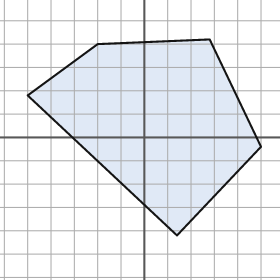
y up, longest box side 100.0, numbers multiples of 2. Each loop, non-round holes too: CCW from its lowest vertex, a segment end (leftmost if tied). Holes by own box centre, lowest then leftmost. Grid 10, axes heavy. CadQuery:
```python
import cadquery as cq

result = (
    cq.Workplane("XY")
    .moveTo(14.0, -42.0)
    .lineTo(50.0, -4.0)
    .lineTo(28.0, 42.0)
    .lineTo(-20.0, 40.0)
    .lineTo(-50.0, 18.0)
    .close()
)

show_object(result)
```